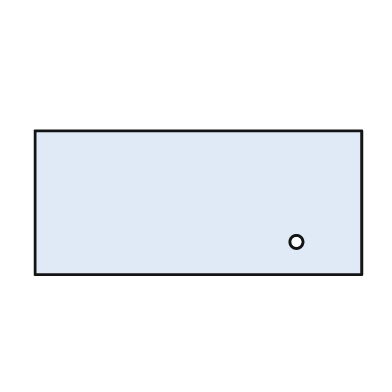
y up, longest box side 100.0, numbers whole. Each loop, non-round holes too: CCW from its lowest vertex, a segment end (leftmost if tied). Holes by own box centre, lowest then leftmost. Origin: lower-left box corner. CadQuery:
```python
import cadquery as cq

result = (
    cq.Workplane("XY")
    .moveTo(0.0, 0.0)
    .lineTo(100.0, 0.0)
    .lineTo(100.0, 44.0)
    .lineTo(0.0, 44.0)
    .close()
    .moveTo(80.0, 10.0)
    .circle(2.0)
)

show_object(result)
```